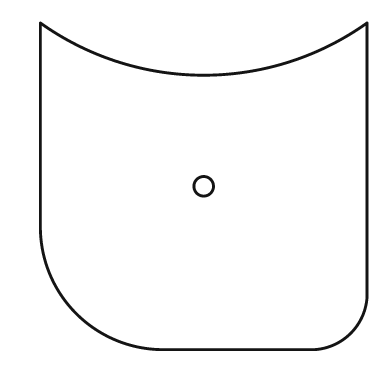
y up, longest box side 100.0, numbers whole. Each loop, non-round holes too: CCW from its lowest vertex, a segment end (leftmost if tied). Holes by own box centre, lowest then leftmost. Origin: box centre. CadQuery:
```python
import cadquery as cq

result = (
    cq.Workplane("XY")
    .moveTo(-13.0, -50.0)
    .lineTo(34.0, -50.0)
    .threePointArc((45.0, -45.0), (50.0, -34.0))
    .lineTo(50.0, 50.0)
    .threePointArc((0.0, 34.0), (-50.0, 50.0))
    .lineTo(-50.0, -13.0)
    .threePointArc((-39.0, -39.0), (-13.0, -50.0))
    .close()
    .moveTo(0.0, 0.0)
    .circle(3.0)
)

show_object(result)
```